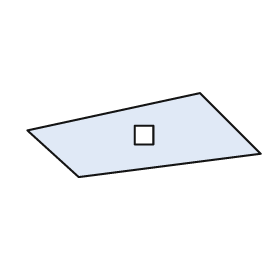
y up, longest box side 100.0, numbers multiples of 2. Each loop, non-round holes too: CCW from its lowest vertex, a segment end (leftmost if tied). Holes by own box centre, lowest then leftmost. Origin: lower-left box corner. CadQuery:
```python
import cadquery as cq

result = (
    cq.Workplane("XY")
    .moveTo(22.0, 0.0)
    .lineTo(100.0, 10.0)
    .lineTo(74.0, 36.0)
    .lineTo(0.0, 20.0)
    .close()
    .moveTo(46.0, 14.0)
    .lineTo(54.0, 14.0)
    .lineTo(54.0, 22.0)
    .lineTo(46.0, 22.0)
    .close()
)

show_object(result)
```